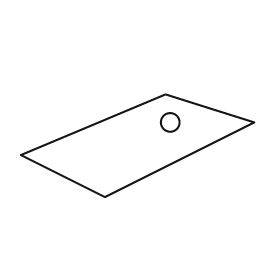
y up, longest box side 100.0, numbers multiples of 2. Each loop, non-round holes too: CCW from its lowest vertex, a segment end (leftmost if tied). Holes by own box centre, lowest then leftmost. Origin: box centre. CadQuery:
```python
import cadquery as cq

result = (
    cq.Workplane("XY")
    .moveTo(-14.0, -22.0)
    .lineTo(50.0, 10.0)
    .lineTo(12.0, 22.0)
    .lineTo(-50.0, -4.0)
    .close()
    .moveTo(14.0, 10.0)
    .circle(4.0)
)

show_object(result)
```